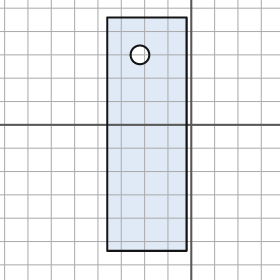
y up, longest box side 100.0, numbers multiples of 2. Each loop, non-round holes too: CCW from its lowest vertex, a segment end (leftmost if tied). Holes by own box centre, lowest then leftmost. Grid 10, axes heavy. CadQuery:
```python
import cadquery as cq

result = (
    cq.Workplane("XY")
    .moveTo(-36.0, -54.0)
    .lineTo(-2.0, -54.0)
    .lineTo(-2.0, 46.0)
    .lineTo(-36.0, 46.0)
    .close()
    .moveTo(-22.0, 30.0)
    .circle(4.0)
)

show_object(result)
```